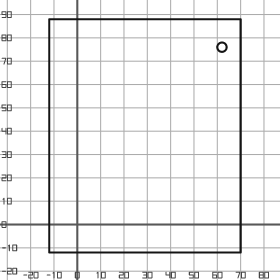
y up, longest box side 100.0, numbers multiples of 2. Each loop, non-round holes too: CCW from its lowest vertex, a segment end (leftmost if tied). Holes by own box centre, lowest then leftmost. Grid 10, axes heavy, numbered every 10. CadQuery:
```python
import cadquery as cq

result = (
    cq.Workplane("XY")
    .moveTo(-12.0, -12.0)
    .lineTo(70.0, -12.0)
    .lineTo(70.0, 88.0)
    .lineTo(-12.0, 88.0)
    .close()
    .moveTo(62.0, 76.0)
    .circle(2.0)
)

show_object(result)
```